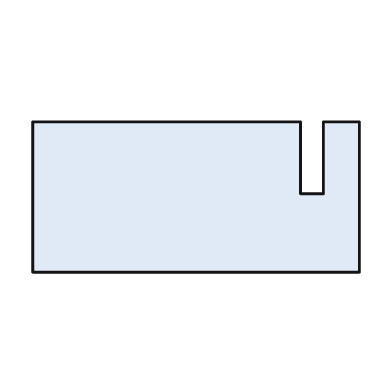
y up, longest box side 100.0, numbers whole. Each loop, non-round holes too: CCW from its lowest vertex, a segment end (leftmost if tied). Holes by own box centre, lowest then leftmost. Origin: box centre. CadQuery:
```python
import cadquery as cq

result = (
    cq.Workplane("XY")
    .moveTo(-50.0, -23.0)
    .lineTo(50.0, -23.0)
    .lineTo(50.0, 23.0)
    .lineTo(39.0, 23.0)
    .lineTo(39.0, 1.0)
    .lineTo(32.0, 1.0)
    .lineTo(32.0, 23.0)
    .lineTo(-50.0, 23.0)
    .close()
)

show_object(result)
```